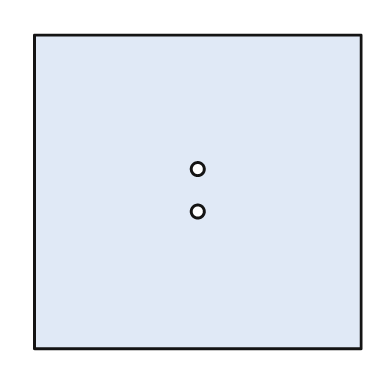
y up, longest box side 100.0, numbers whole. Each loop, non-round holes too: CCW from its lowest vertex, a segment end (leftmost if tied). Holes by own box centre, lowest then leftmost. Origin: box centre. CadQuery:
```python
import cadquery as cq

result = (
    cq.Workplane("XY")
    .moveTo(-50.0, -48.0)
    .lineTo(50.0, -48.0)
    .lineTo(50.0, 48.0)
    .lineTo(-50.0, 48.0)
    .close()
    .moveTo(0.0, -6.0)
    .circle(2.0)
    .moveTo(0.0, 7.0)
    .circle(2.0)
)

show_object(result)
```